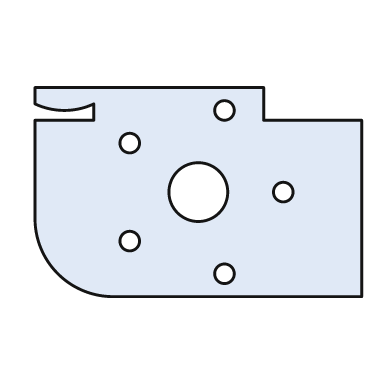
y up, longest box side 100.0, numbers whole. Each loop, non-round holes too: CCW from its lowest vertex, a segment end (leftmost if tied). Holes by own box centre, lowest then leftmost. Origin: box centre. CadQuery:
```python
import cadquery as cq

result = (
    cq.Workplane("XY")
    .moveTo(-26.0, -32.0)
    .lineTo(50.0, -32.0)
    .lineTo(50.0, 22.0)
    .lineTo(20.0, 22.0)
    .lineTo(20.0, 32.0)
    .lineTo(-50.0, 32.0)
    .lineTo(-50.0, 27.0)
    .threePointArc((-41.0, 25.0), (-32.0, 27.0))
    .lineTo(-32.0, 22.0)
    .lineTo(-50.0, 22.0)
    .lineTo(-50.0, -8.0)
    .threePointArc((-43.0, -25.0), (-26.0, -32.0))
    .close()
    .moveTo(8.0, -25.0)
    .circle(3.0)
    .moveTo(-21.0, -15.0)
    .circle(3.0)
    .moveTo(0.0, 0.0)
    .circle(9.0)
    .moveTo(26.0, 0.0)
    .circle(3.0)
    .moveTo(-21.0, 15.0)
    .circle(3.0)
    .moveTo(8.0, 25.0)
    .circle(3.0)
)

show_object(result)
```